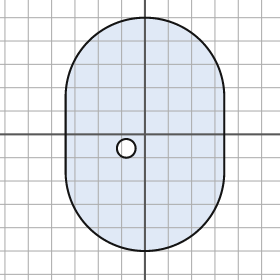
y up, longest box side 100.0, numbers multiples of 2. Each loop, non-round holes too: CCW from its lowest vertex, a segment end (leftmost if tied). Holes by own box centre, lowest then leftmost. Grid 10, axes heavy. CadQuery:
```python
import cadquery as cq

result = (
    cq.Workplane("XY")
    .moveTo(-34.0, -16.0)
    .threePointArc((0.0, -50.0), (34.0, -16.0))
    .lineTo(34.0, 16.0)
    .threePointArc((0.0, 50.0), (-34.0, 16.0))
    .close()
    .moveTo(-8.0, -6.0)
    .circle(4.0)
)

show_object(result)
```